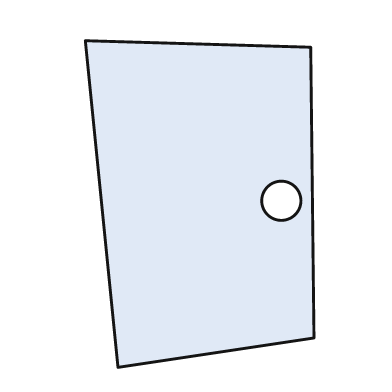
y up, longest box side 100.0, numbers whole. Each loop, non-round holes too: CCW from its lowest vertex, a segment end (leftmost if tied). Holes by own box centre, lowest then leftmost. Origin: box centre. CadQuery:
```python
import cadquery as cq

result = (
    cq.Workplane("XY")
    .moveTo(-25.0, -50.0)
    .lineTo(35.0, -41.0)
    .lineTo(34.0, 48.0)
    .lineTo(-35.0, 50.0)
    .close()
    .moveTo(25.0, 1.0)
    .circle(6.0)
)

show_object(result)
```